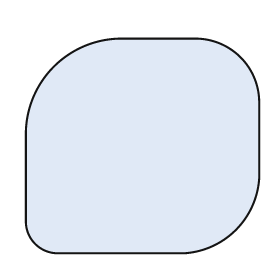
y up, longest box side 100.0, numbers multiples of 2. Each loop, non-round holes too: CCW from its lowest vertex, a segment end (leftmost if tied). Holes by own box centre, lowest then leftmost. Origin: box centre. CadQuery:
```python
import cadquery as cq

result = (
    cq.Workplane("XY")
    .moveTo(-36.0, -46.0)
    .lineTo(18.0, -46.0)
    .threePointArc((40.0, -36.0), (50.0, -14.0))
    .lineTo(50.0, 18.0)
    .threePointArc((42.0, 38.0), (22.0, 46.0))
    .lineTo(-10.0, 46.0)
    .threePointArc((-38.0, 34.0), (-50.0, 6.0))
    .lineTo(-50.0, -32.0)
    .threePointArc((-46.0, -42.0), (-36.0, -46.0))
    .close()
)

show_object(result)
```